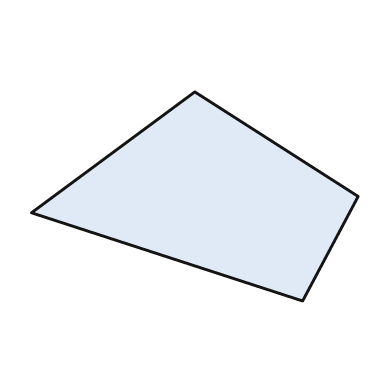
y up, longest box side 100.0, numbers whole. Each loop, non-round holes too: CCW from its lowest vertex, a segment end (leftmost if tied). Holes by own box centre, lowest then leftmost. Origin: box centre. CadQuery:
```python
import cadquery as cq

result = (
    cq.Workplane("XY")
    .moveTo(33.0, -32.0)
    .lineTo(50.0, 0.0)
    .lineTo(0.0, 32.0)
    .lineTo(-50.0, -5.0)
    .close()
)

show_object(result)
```